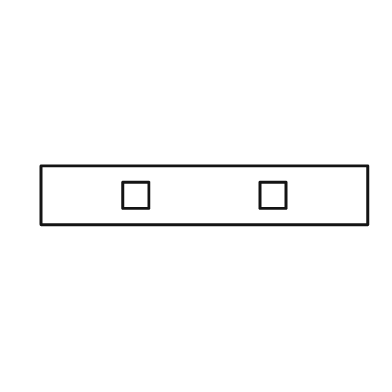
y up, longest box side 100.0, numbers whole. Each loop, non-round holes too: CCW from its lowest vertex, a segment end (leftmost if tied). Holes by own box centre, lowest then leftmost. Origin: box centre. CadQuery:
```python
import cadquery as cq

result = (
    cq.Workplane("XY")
    .moveTo(-50.0, -9.0)
    .lineTo(50.0, -9.0)
    .lineTo(50.0, 9.0)
    .lineTo(-50.0, 9.0)
    .close()
    .moveTo(-25.0, -4.0)
    .lineTo(-17.0, -4.0)
    .lineTo(-17.0, 4.0)
    .lineTo(-25.0, 4.0)
    .close()
    .moveTo(17.0, -4.0)
    .lineTo(25.0, -4.0)
    .lineTo(25.0, 4.0)
    .lineTo(17.0, 4.0)
    .close()
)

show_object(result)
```